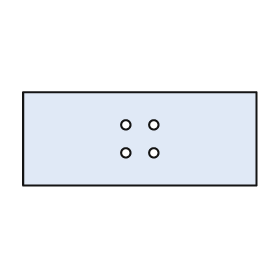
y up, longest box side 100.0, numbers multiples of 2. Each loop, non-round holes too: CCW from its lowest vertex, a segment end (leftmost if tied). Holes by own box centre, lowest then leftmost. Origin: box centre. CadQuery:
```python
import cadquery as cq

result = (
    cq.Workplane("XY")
    .moveTo(-50.0, -20.0)
    .lineTo(50.0, -20.0)
    .lineTo(50.0, 20.0)
    .lineTo(-50.0, 20.0)
    .close()
    .moveTo(-6.0, -6.0)
    .circle(2.0)
    .moveTo(6.0, -6.0)
    .circle(2.0)
    .moveTo(-6.0, 6.0)
    .circle(2.0)
    .moveTo(6.0, 6.0)
    .circle(2.0)
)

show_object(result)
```